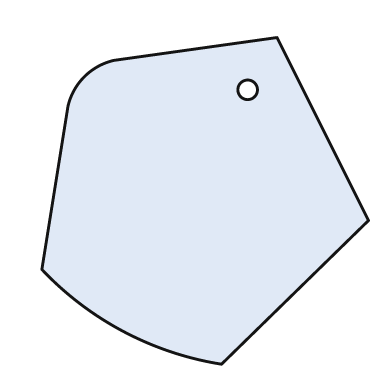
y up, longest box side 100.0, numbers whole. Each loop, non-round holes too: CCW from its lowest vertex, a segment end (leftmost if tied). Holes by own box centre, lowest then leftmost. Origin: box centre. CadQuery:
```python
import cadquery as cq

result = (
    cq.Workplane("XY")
    .moveTo(5.0, -50.0)
    .lineTo(50.0, -6.0)
    .lineTo(22.0, 50.0)
    .lineTo(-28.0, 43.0)
    .threePointArc((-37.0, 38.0), (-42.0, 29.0))
    .lineTo(-50.0, -21.0)
    .threePointArc((-25.0, -40.0), (5.0, -50.0))
    .close()
    .moveTo(13.0, 34.0)
    .circle(3.0)
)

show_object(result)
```